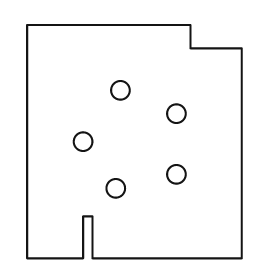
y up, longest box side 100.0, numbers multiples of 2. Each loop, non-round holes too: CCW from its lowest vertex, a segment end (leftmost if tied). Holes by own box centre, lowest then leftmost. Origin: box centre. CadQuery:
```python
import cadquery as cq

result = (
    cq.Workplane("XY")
    .moveTo(-46.0, -50.0)
    .lineTo(-22.0, -50.0)
    .lineTo(-22.0, -32.0)
    .lineTo(-18.0, -32.0)
    .lineTo(-18.0, -50.0)
    .lineTo(46.0, -50.0)
    .lineTo(46.0, 40.0)
    .lineTo(24.0, 40.0)
    .lineTo(24.0, 50.0)
    .lineTo(-46.0, 50.0)
    .close()
    .moveTo(-8.0, -20.0)
    .circle(4.0)
    .moveTo(18.0, -14.0)
    .circle(4.0)
    .moveTo(-22.0, 0.0)
    .circle(4.0)
    .moveTo(18.0, 12.0)
    .circle(4.0)
    .moveTo(-6.0, 22.0)
    .circle(4.0)
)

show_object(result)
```